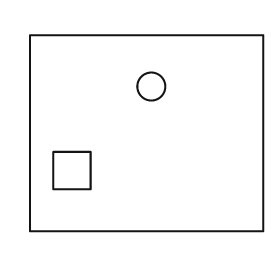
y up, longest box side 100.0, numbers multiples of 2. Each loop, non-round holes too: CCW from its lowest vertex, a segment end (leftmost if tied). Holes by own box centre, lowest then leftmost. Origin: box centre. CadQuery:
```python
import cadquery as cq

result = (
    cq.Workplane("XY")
    .moveTo(-50.0, -42.0)
    .lineTo(50.0, -42.0)
    .lineTo(50.0, 42.0)
    .lineTo(-50.0, 42.0)
    .close()
    .moveTo(-40.0, -24.0)
    .lineTo(-24.0, -24.0)
    .lineTo(-24.0, -8.0)
    .lineTo(-40.0, -8.0)
    .close()
    .moveTo(2.0, 20.0)
    .circle(6.0)
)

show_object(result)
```